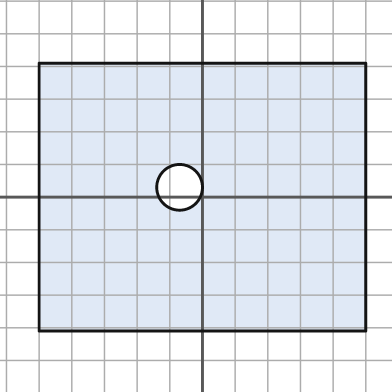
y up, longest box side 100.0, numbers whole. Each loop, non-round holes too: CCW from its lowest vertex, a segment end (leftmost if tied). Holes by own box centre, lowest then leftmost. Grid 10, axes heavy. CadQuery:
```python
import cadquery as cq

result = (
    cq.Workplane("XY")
    .moveTo(-50.0, -41.0)
    .lineTo(50.0, -41.0)
    .lineTo(50.0, 41.0)
    .lineTo(-50.0, 41.0)
    .close()
    .moveTo(-7.0, 3.0)
    .circle(7.0)
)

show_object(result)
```